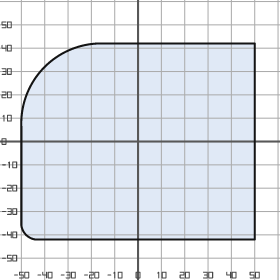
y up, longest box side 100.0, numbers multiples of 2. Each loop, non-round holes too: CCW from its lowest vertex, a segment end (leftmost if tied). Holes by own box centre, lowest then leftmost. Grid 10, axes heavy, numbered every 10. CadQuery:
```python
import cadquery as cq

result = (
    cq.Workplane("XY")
    .moveTo(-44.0, -42.0)
    .lineTo(50.0, -42.0)
    .lineTo(50.0, 42.0)
    .lineTo(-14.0, 42.0)
    .threePointArc((-40.0, 32.0), (-50.0, 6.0))
    .lineTo(-50.0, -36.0)
    .threePointArc((-48.0, -40.0), (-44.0, -42.0))
    .close()
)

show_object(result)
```